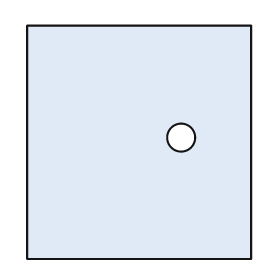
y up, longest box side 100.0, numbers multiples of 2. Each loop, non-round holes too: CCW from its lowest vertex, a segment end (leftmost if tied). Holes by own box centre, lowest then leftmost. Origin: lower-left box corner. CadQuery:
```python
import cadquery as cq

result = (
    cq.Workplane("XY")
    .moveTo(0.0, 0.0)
    .lineTo(96.0, 0.0)
    .lineTo(96.0, 100.0)
    .lineTo(0.0, 100.0)
    .close()
    .moveTo(66.0, 52.0)
    .circle(6.0)
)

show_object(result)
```